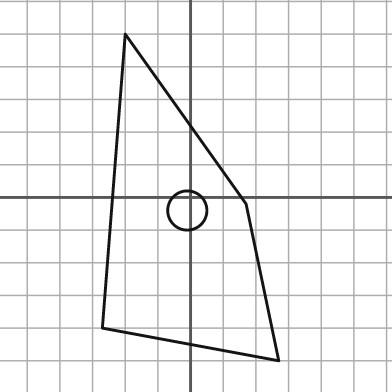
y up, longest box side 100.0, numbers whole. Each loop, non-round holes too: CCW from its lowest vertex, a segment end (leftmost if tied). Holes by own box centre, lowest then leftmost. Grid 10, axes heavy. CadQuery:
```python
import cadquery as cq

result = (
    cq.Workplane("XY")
    .moveTo(27.0, -50.0)
    .lineTo(17.0, -2.0)
    .lineTo(-20.0, 50.0)
    .lineTo(-27.0, -40.0)
    .close()
    .moveTo(-1.0, -4.0)
    .circle(6.0)
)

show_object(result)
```